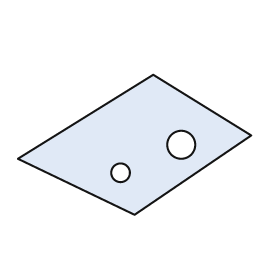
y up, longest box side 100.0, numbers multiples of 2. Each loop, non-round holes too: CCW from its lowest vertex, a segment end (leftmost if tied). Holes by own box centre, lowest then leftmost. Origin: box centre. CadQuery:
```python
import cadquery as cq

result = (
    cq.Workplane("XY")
    .moveTo(0.0, -30.0)
    .lineTo(50.0, 4.0)
    .lineTo(8.0, 30.0)
    .lineTo(-50.0, -6.0)
    .close()
    .moveTo(-6.0, -12.0)
    .circle(4.0)
    .moveTo(20.0, 0.0)
    .circle(6.0)
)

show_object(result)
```